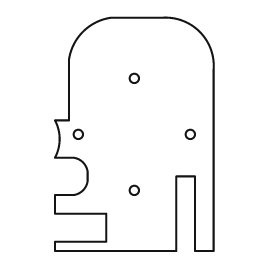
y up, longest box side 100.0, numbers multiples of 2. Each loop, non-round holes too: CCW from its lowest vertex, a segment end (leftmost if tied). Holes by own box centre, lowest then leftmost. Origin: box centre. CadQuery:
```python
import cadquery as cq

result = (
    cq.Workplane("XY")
    .moveTo(-34.0, -50.0)
    .lineTo(18.0, -50.0)
    .lineTo(18.0, -18.0)
    .lineTo(26.0, -18.0)
    .lineTo(26.0, -50.0)
    .lineTo(34.0, -50.0)
    .lineTo(34.0, 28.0)
    .threePointArc((28.0, 44.0), (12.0, 50.0))
    .lineTo(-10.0, 50.0)
    .threePointArc((-22.0, 44.0), (-28.0, 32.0))
    .lineTo(-28.0, 6.0)
    .lineTo(-34.0, 6.0)
    .threePointArc((-32.0, -2.0), (-34.0, -10.0))
    .lineTo(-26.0, -10.0)
    .threePointArc((-22.0, -12.0), (-20.0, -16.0))
    .lineTo(-20.0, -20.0)
    .threePointArc((-22.0, -24.0), (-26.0, -26.0))
    .lineTo(-34.0, -26.0)
    .lineTo(-34.0, -34.0)
    .lineTo(-12.0, -34.0)
    .lineTo(-12.0, -46.0)
    .lineTo(-34.0, -46.0)
    .close()
    .moveTo(0.0, -24.0)
    .circle(2.0)
    .moveTo(-24.0, 0.0)
    .circle(2.0)
    .moveTo(24.0, 0.0)
    .circle(2.0)
    .moveTo(0.0, 24.0)
    .circle(2.0)
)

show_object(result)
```